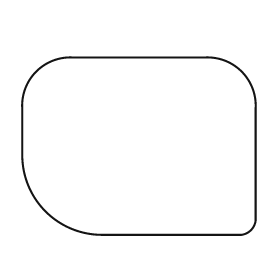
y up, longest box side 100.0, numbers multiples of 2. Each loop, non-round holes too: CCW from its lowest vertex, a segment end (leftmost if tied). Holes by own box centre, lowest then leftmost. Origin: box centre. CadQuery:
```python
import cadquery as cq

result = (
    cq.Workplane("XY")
    .moveTo(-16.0, -38.0)
    .lineTo(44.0, -38.0)
    .threePointArc((48.0, -36.0), (50.0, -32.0))
    .lineTo(50.0, 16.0)
    .threePointArc((44.0, 32.0), (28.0, 38.0))
    .lineTo(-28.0, 38.0)
    .threePointArc((-44.0, 32.0), (-50.0, 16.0))
    .lineTo(-50.0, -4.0)
    .threePointArc((-40.0, -28.0), (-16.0, -38.0))
    .close()
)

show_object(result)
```